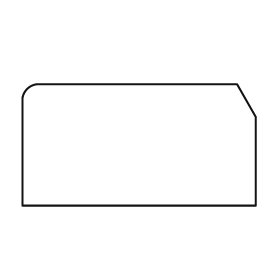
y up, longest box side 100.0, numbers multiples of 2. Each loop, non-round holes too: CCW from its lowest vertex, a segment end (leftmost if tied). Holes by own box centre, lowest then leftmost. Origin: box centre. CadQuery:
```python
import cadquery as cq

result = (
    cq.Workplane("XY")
    .moveTo(-50.0, -26.0)
    .lineTo(50.0, -26.0)
    .lineTo(50.0, 12.0)
    .lineTo(42.0, 26.0)
    .lineTo(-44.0, 26.0)
    .threePointArc((-48.0, 24.0), (-50.0, 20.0))
    .close()
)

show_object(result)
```